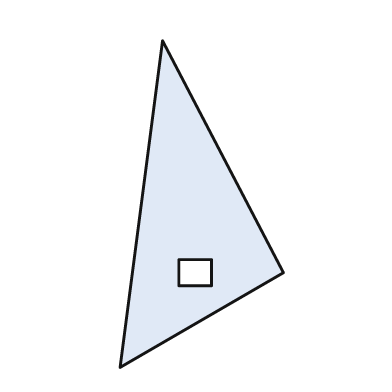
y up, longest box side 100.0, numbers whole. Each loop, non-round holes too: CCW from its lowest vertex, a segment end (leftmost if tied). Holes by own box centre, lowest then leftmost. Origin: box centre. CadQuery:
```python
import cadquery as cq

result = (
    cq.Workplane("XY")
    .moveTo(-25.0, -50.0)
    .lineTo(25.0, -21.0)
    .lineTo(-12.0, 50.0)
    .close()
    .moveTo(-7.0, -25.0)
    .lineTo(3.0, -25.0)
    .lineTo(3.0, -17.0)
    .lineTo(-7.0, -17.0)
    .close()
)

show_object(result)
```